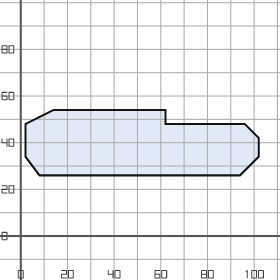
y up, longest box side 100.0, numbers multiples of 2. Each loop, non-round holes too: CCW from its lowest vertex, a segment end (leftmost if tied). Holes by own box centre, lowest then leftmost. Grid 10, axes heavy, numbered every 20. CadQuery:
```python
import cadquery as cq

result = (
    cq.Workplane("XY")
    .moveTo(8.0, 26.0)
    .lineTo(94.0, 26.0)
    .lineTo(102.0, 34.0)
    .lineTo(102.0, 42.0)
    .lineTo(96.0, 48.0)
    .lineTo(62.0, 48.0)
    .lineTo(62.0, 54.0)
    .lineTo(14.0, 54.0)
    .lineTo(2.0, 48.0)
    .lineTo(2.0, 34.0)
    .close()
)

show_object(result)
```